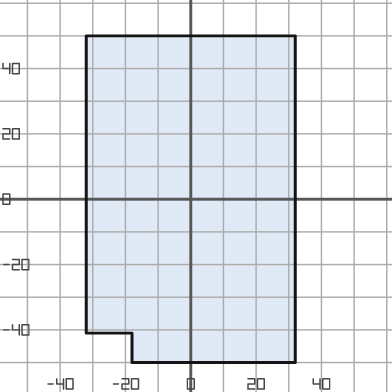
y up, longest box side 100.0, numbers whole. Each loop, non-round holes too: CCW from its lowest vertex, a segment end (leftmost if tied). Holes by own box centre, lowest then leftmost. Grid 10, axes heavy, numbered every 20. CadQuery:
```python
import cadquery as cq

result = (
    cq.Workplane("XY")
    .moveTo(-18.0, -50.0)
    .lineTo(32.0, -50.0)
    .lineTo(32.0, 50.0)
    .lineTo(-32.0, 50.0)
    .lineTo(-32.0, -41.0)
    .lineTo(-18.0, -41.0)
    .close()
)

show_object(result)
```